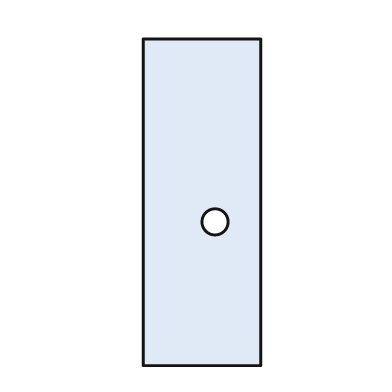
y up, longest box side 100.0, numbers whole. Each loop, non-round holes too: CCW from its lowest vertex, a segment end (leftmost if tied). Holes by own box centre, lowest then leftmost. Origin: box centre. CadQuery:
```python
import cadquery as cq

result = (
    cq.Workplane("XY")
    .moveTo(-18.0, -50.0)
    .lineTo(18.0, -50.0)
    .lineTo(18.0, 50.0)
    .lineTo(-18.0, 50.0)
    .close()
    .moveTo(4.0, -6.0)
    .circle(4.0)
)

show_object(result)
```